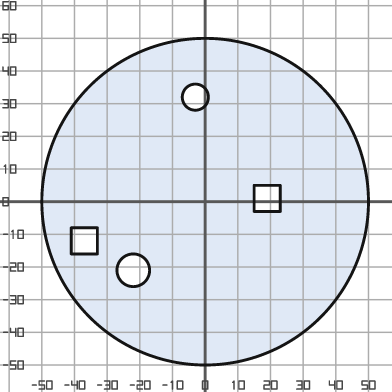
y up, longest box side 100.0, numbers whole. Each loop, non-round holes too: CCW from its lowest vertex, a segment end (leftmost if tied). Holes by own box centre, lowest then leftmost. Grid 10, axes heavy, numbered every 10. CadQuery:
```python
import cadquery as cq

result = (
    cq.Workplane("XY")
    .moveTo(0.0, 0.0)
    .circle(50.0)
    .moveTo(-22.0, -21.0)
    .circle(5.0)
    .moveTo(-41.0, -16.0)
    .lineTo(-33.0, -16.0)
    .lineTo(-33.0, -8.0)
    .lineTo(-41.0, -8.0)
    .close()
    .moveTo(15.0, -3.0)
    .lineTo(23.0, -3.0)
    .lineTo(23.0, 5.0)
    .lineTo(15.0, 5.0)
    .close()
    .moveTo(-3.0, 32.0)
    .circle(4.0)
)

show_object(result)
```